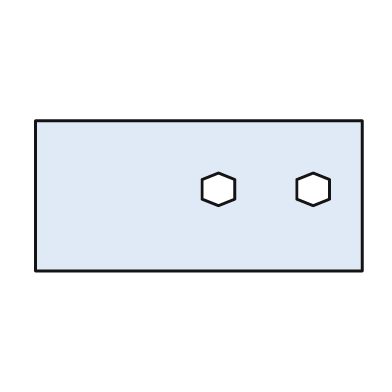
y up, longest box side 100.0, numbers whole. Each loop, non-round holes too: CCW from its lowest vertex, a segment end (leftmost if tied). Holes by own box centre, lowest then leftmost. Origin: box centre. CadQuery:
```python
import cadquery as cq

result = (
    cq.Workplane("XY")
    .moveTo(-50.0, -23.0)
    .lineTo(50.0, -23.0)
    .lineTo(50.0, 23.0)
    .lineTo(-50.0, 23.0)
    .close()
    .moveTo(6.0, -3.0)
    .lineTo(11.0, -1.0)
    .lineTo(11.0, 5.0)
    .lineTo(6.0, 7.0)
    .lineTo(1.0, 5.0)
    .lineTo(1.0, -1.0)
    .close()
    .moveTo(35.0, -3.0)
    .lineTo(40.0, -1.0)
    .lineTo(40.0, 5.0)
    .lineTo(35.0, 7.0)
    .lineTo(30.0, 5.0)
    .lineTo(30.0, -1.0)
    .close()
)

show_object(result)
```